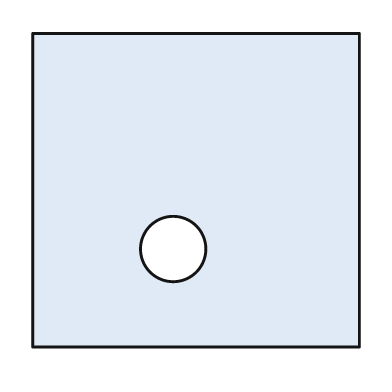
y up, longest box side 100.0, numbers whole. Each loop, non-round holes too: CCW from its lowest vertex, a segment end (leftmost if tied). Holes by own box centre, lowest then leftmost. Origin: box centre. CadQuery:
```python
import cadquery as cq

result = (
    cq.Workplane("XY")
    .moveTo(-50.0, -48.0)
    .lineTo(50.0, -48.0)
    .lineTo(50.0, 48.0)
    .lineTo(-50.0, 48.0)
    .close()
    .moveTo(-7.0, -18.0)
    .circle(10.0)
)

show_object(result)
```